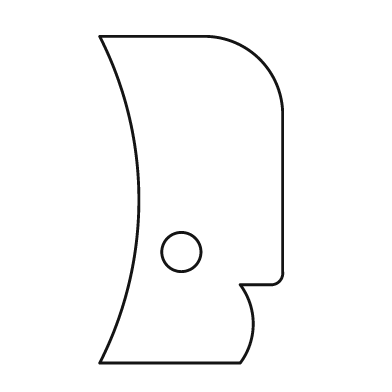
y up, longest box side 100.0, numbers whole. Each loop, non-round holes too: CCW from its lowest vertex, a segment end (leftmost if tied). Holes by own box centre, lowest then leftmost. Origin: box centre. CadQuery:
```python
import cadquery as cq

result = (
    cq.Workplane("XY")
    .moveTo(-28.0, -50.0)
    .lineTo(15.0, -50.0)
    .threePointArc((19.0, -38.0), (15.0, -26.0))
    .lineTo(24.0, -26.0)
    .threePointArc((27.0, -25.0), (28.0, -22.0))
    .lineTo(28.0, 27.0)
    .threePointArc((21.0, 43.0), (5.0, 50.0))
    .lineTo(-28.0, 50.0)
    .threePointArc((-16.0, 0.0), (-28.0, -50.0))
    .close()
    .moveTo(-3.0, -16.0)
    .circle(6.0)
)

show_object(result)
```